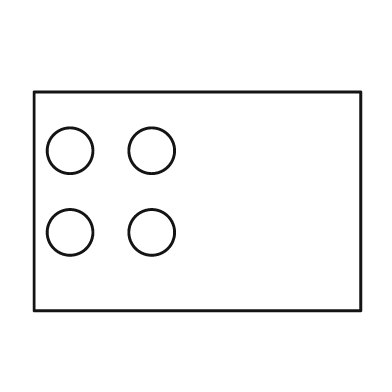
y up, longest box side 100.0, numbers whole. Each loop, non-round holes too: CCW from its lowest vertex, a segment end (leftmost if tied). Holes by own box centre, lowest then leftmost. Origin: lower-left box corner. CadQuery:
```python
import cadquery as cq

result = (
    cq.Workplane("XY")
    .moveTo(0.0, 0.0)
    .lineTo(100.0, 0.0)
    .lineTo(100.0, 67.0)
    .lineTo(0.0, 67.0)
    .close()
    .moveTo(11.0, 24.0)
    .circle(7.0)
    .moveTo(36.0, 24.0)
    .circle(7.0)
    .moveTo(11.0, 49.0)
    .circle(7.0)
    .moveTo(36.0, 49.0)
    .circle(7.0)
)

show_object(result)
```